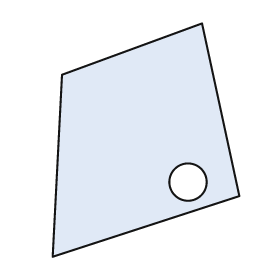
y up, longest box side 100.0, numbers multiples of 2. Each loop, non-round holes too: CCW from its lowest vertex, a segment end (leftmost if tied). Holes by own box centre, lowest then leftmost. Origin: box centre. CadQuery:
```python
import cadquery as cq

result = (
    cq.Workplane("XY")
    .moveTo(-40.0, -50.0)
    .lineTo(40.0, -24.0)
    .lineTo(24.0, 50.0)
    .lineTo(-36.0, 28.0)
    .close()
    .moveTo(18.0, -18.0)
    .circle(8.0)
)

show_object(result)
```